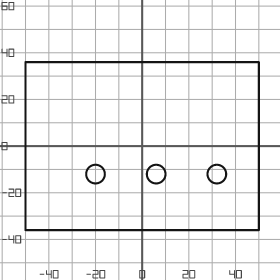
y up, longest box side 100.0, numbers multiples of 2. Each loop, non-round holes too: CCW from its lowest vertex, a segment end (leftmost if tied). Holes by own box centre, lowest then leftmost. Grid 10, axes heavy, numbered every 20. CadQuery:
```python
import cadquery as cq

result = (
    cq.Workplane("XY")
    .moveTo(-50.0, -36.0)
    .lineTo(50.0, -36.0)
    .lineTo(50.0, 36.0)
    .lineTo(-50.0, 36.0)
    .close()
    .moveTo(-20.0, -12.0)
    .circle(4.0)
    .moveTo(6.0, -12.0)
    .circle(4.0)
    .moveTo(32.0, -12.0)
    .circle(4.0)
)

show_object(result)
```